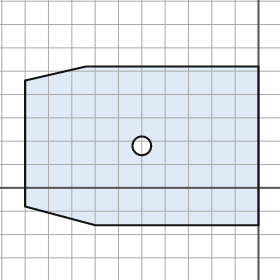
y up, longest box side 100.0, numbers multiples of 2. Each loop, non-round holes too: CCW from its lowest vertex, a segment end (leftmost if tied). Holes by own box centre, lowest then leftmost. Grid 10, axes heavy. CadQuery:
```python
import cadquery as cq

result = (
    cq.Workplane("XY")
    .moveTo(-70.0, -16.0)
    .lineTo(0.0, -16.0)
    .lineTo(0.0, 52.0)
    .lineTo(-74.0, 52.0)
    .lineTo(-100.0, 46.0)
    .lineTo(-100.0, -8.0)
    .close()
    .moveTo(-50.0, 18.0)
    .circle(4.0)
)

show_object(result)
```